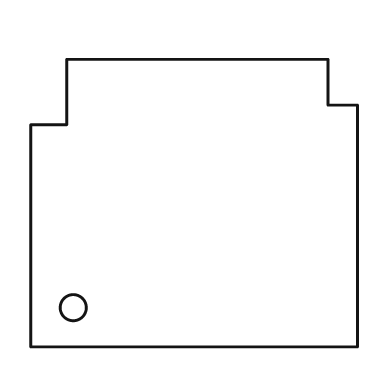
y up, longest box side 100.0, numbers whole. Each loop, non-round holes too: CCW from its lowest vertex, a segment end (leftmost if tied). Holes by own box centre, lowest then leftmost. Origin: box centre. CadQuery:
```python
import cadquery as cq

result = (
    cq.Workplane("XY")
    .moveTo(-50.0, -44.0)
    .lineTo(50.0, -44.0)
    .lineTo(50.0, 30.0)
    .lineTo(41.0, 30.0)
    .lineTo(41.0, 44.0)
    .lineTo(-39.0, 44.0)
    .lineTo(-39.0, 24.0)
    .lineTo(-50.0, 24.0)
    .close()
    .moveTo(-37.0, -32.0)
    .circle(4.0)
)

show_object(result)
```